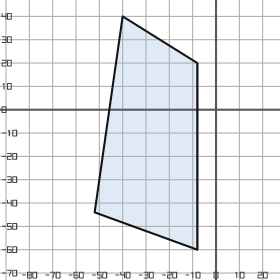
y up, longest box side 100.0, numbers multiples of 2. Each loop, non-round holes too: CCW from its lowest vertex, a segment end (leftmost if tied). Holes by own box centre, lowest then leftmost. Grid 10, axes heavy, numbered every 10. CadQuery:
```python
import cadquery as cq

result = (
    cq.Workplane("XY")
    .moveTo(-8.0, -60.0)
    .lineTo(-8.0, 20.0)
    .lineTo(-40.0, 40.0)
    .lineTo(-52.0, -44.0)
    .close()
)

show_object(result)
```